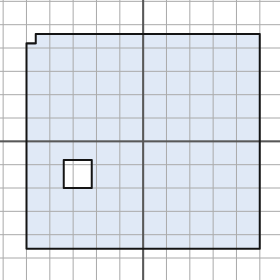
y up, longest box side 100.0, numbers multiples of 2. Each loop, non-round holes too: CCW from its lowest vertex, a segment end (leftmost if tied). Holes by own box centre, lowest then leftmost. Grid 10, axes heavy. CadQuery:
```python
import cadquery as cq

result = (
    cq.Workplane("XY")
    .moveTo(-50.0, -46.0)
    .lineTo(50.0, -46.0)
    .lineTo(50.0, 46.0)
    .lineTo(-46.0, 46.0)
    .lineTo(-46.0, 42.0)
    .lineTo(-50.0, 42.0)
    .close()
    .moveTo(-34.0, -20.0)
    .lineTo(-22.0, -20.0)
    .lineTo(-22.0, -8.0)
    .lineTo(-34.0, -8.0)
    .close()
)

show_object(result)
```